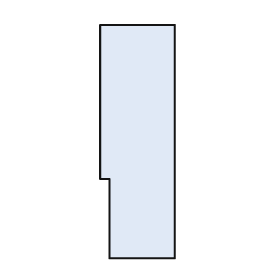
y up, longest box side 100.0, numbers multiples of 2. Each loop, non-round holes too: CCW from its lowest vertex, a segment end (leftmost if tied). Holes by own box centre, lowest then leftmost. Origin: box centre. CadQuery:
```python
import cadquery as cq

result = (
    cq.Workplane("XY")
    .moveTo(-12.0, -50.0)
    .lineTo(16.0, -50.0)
    .lineTo(16.0, 50.0)
    .lineTo(-16.0, 50.0)
    .lineTo(-16.0, -16.0)
    .lineTo(-12.0, -16.0)
    .close()
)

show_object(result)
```